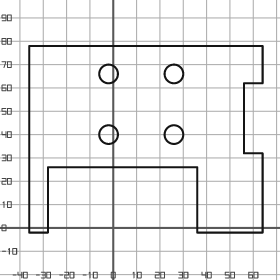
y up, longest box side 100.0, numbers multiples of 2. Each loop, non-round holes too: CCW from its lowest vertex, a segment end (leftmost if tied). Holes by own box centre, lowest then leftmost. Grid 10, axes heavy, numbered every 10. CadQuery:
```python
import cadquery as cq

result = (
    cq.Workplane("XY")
    .moveTo(-36.0, -2.0)
    .lineTo(-28.0, -2.0)
    .lineTo(-28.0, 26.0)
    .lineTo(36.0, 26.0)
    .lineTo(36.0, -2.0)
    .lineTo(64.0, -2.0)
    .lineTo(64.0, 32.0)
    .lineTo(56.0, 32.0)
    .lineTo(56.0, 62.0)
    .lineTo(64.0, 62.0)
    .lineTo(64.0, 78.0)
    .lineTo(-36.0, 78.0)
    .close()
    .moveTo(-2.0, 40.0)
    .circle(4.0)
    .moveTo(26.0, 40.0)
    .circle(4.0)
    .moveTo(-2.0, 66.0)
    .circle(4.0)
    .moveTo(26.0, 66.0)
    .circle(4.0)
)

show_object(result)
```